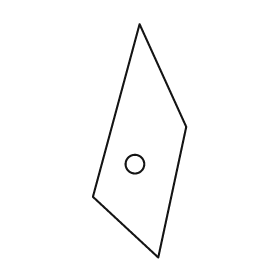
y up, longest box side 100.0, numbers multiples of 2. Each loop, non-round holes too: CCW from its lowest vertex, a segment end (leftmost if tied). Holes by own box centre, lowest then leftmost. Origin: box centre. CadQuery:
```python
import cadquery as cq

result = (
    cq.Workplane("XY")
    .moveTo(8.0, -50.0)
    .lineTo(20.0, 6.0)
    .lineTo(0.0, 50.0)
    .lineTo(-20.0, -24.0)
    .close()
    .moveTo(-2.0, -10.0)
    .circle(4.0)
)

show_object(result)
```